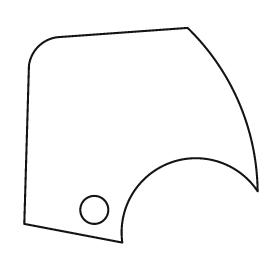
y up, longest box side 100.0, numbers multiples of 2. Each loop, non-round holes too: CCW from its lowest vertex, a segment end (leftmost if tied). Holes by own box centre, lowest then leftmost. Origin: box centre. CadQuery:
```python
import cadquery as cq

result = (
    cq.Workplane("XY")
    .moveTo(-8.0, -46.0)
    .threePointArc((12.0, -12.0), (50.0, -24.0))
    .threePointArc((42.0, 14.0), (20.0, 46.0))
    .lineTo(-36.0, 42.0)
    .threePointArc((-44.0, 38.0), (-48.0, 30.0))
    .lineTo(-50.0, -38.0)
    .close()
    .moveTo(-20.0, -32.0)
    .circle(6.0)
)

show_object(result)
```